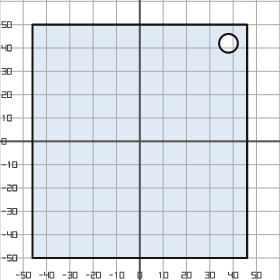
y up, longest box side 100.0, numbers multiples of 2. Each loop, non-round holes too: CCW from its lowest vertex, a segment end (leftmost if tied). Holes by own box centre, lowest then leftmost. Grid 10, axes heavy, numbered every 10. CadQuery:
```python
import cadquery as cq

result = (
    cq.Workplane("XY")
    .moveTo(-46.0, -50.0)
    .lineTo(46.0, -50.0)
    .lineTo(46.0, 50.0)
    .lineTo(-46.0, 50.0)
    .close()
    .moveTo(38.0, 42.0)
    .circle(4.0)
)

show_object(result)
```